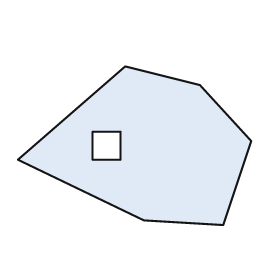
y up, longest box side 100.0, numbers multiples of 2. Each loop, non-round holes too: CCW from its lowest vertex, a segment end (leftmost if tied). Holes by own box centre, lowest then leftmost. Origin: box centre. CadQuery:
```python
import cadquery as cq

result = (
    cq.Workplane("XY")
    .moveTo(38.0, -34.0)
    .lineTo(50.0, 2.0)
    .lineTo(28.0, 26.0)
    .lineTo(-4.0, 34.0)
    .lineTo(-50.0, -6.0)
    .lineTo(4.0, -32.0)
    .close()
    .moveTo(-18.0, -6.0)
    .lineTo(-6.0, -6.0)
    .lineTo(-6.0, 6.0)
    .lineTo(-18.0, 6.0)
    .close()
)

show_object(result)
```